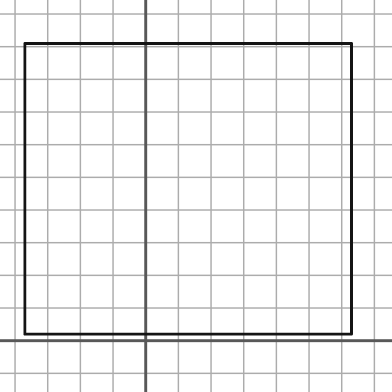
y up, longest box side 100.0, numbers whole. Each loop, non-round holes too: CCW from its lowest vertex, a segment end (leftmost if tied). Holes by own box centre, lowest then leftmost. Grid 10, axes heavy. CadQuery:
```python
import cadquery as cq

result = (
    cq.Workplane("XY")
    .moveTo(-37.0, 2.0)
    .lineTo(63.0, 2.0)
    .lineTo(63.0, 91.0)
    .lineTo(-37.0, 91.0)
    .close()
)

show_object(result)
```